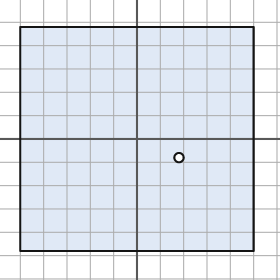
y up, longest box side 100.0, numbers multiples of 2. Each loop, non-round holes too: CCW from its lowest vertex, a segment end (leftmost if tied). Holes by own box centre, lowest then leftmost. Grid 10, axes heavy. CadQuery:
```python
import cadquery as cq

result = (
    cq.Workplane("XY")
    .moveTo(-50.0, -48.0)
    .lineTo(50.0, -48.0)
    .lineTo(50.0, 48.0)
    .lineTo(-50.0, 48.0)
    .close()
    .moveTo(18.0, -8.0)
    .circle(2.0)
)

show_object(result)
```